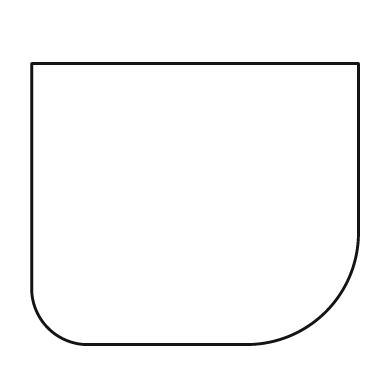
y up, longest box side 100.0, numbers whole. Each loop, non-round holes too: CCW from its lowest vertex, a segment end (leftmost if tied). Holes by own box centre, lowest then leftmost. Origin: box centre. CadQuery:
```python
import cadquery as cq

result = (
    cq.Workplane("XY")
    .moveTo(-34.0, -43.0)
    .lineTo(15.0, -43.0)
    .threePointArc((40.0, -33.0), (50.0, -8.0))
    .lineTo(50.0, 43.0)
    .lineTo(-50.0, 43.0)
    .lineTo(-50.0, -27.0)
    .threePointArc((-45.0, -38.0), (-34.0, -43.0))
    .close()
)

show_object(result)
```